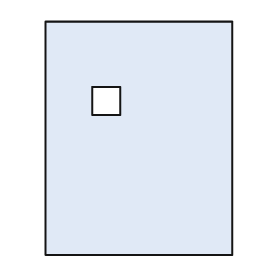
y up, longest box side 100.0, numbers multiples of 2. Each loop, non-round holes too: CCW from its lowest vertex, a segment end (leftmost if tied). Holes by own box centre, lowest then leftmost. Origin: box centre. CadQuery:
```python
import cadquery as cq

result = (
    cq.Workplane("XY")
    .moveTo(-40.0, -50.0)
    .lineTo(40.0, -50.0)
    .lineTo(40.0, 50.0)
    .lineTo(-40.0, 50.0)
    .close()
    .moveTo(-20.0, 10.0)
    .lineTo(-8.0, 10.0)
    .lineTo(-8.0, 22.0)
    .lineTo(-20.0, 22.0)
    .close()
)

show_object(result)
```